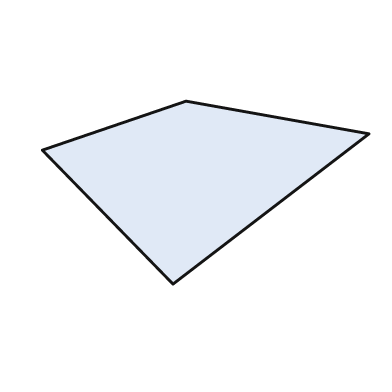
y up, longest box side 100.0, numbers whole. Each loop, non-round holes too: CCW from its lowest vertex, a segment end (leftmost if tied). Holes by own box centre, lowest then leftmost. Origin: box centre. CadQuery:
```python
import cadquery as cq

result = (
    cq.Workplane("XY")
    .moveTo(-10.0, -28.0)
    .lineTo(50.0, 18.0)
    .lineTo(-6.0, 28.0)
    .lineTo(-50.0, 13.0)
    .close()
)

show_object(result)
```